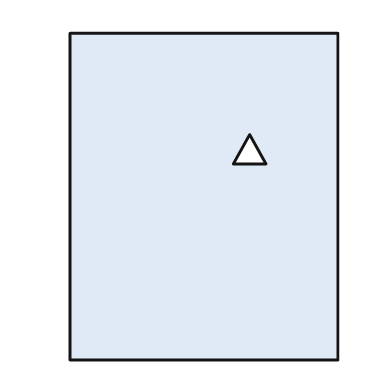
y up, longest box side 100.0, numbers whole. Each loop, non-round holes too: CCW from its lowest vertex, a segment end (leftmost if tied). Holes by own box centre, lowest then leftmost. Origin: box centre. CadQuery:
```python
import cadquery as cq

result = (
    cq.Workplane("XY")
    .moveTo(-41.0, -50.0)
    .lineTo(41.0, -50.0)
    .lineTo(41.0, 50.0)
    .lineTo(-41.0, 50.0)
    .close()
    .moveTo(9.0, 10.0)
    .lineTo(19.0, 10.0)
    .lineTo(14.0, 19.0)
    .close()
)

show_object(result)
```